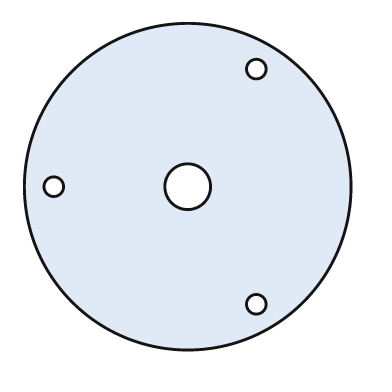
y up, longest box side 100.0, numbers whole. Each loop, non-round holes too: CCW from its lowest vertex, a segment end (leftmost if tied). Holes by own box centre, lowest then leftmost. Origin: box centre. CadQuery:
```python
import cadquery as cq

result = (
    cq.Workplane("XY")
    .moveTo(0.0, 0.0)
    .circle(50.0)
    .moveTo(21.0, -36.0)
    .circle(3.0)
    .moveTo(-41.0, 0.0)
    .circle(3.0)
    .moveTo(0.0, 0.0)
    .circle(7.0)
    .moveTo(21.0, 36.0)
    .circle(3.0)
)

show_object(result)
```